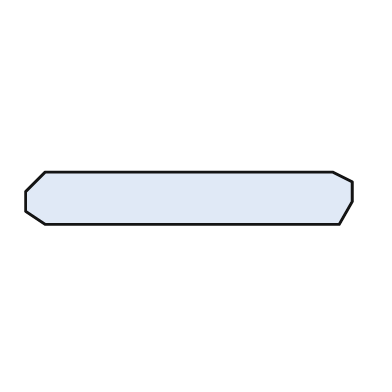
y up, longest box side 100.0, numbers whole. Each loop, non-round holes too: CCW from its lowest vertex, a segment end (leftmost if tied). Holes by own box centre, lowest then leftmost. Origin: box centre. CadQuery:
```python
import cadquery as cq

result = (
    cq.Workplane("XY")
    .moveTo(-44.0, -8.0)
    .lineTo(46.0, -8.0)
    .lineTo(50.0, -1.0)
    .lineTo(50.0, 5.0)
    .lineTo(44.0, 8.0)
    .lineTo(-44.0, 8.0)
    .lineTo(-50.0, 2.0)
    .lineTo(-50.0, -4.0)
    .close()
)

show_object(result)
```